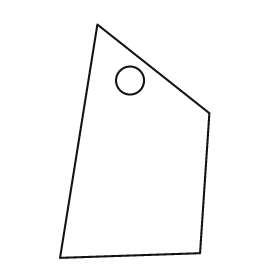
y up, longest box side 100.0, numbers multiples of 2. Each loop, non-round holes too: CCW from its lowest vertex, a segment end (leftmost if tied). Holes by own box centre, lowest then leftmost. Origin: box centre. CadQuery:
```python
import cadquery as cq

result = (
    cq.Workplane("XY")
    .moveTo(-32.0, -50.0)
    .lineTo(28.0, -48.0)
    .lineTo(32.0, 12.0)
    .lineTo(-16.0, 50.0)
    .close()
    .moveTo(-2.0, 26.0)
    .circle(6.0)
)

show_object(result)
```